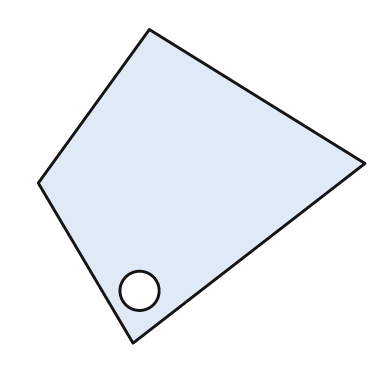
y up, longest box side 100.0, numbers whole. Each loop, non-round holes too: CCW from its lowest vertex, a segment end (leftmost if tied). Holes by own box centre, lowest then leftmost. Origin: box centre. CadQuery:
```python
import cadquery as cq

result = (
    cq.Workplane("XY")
    .moveTo(-21.0, -48.0)
    .lineTo(50.0, 7.0)
    .lineTo(-16.0, 48.0)
    .lineTo(-50.0, 1.0)
    .close()
    .moveTo(-19.0, -32.0)
    .circle(6.0)
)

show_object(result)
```